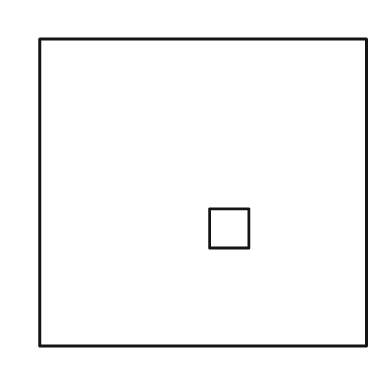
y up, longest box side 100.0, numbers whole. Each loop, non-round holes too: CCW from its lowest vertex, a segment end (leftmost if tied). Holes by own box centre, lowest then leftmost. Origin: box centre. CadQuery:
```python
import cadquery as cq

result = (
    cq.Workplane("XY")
    .moveTo(-50.0, -47.0)
    .lineTo(50.0, -47.0)
    .lineTo(50.0, 47.0)
    .lineTo(-50.0, 47.0)
    .close()
    .moveTo(2.0, -17.0)
    .lineTo(14.0, -17.0)
    .lineTo(14.0, -5.0)
    .lineTo(2.0, -5.0)
    .close()
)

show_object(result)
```